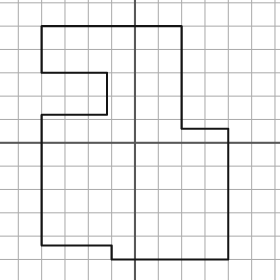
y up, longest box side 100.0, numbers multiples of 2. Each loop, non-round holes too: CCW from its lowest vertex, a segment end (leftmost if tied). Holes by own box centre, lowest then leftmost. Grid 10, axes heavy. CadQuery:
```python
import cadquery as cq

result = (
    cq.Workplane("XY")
    .moveTo(-10.0, -50.0)
    .lineTo(40.0, -50.0)
    .lineTo(40.0, 6.0)
    .lineTo(20.0, 6.0)
    .lineTo(20.0, 50.0)
    .lineTo(-40.0, 50.0)
    .lineTo(-40.0, 30.0)
    .lineTo(-12.0, 30.0)
    .lineTo(-12.0, 12.0)
    .lineTo(-40.0, 12.0)
    .lineTo(-40.0, -44.0)
    .lineTo(-10.0, -44.0)
    .close()
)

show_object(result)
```